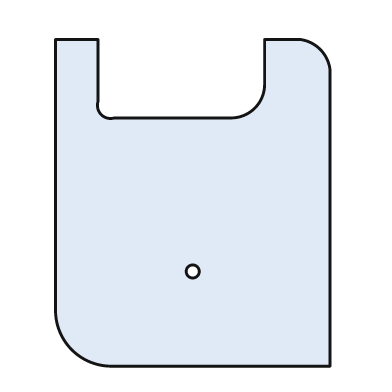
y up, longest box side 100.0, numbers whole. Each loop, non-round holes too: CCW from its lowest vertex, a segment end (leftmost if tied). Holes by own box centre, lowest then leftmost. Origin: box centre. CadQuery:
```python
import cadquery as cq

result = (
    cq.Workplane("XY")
    .moveTo(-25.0, -50.0)
    .lineTo(42.0, -50.0)
    .lineTo(42.0, 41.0)
    .threePointArc((39.0, 47.0), (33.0, 50.0))
    .lineTo(22.0, 50.0)
    .lineTo(22.0, 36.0)
    .threePointArc((19.0, 29.0), (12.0, 26.0))
    .lineTo(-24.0, 26.0)
    .threePointArc((-28.0, 27.0), (-29.0, 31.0))
    .lineTo(-29.0, 50.0)
    .lineTo(-42.0, 50.0)
    .lineTo(-42.0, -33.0)
    .threePointArc((-37.0, -45.0), (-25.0, -50.0))
    .close()
    .moveTo(0.0, -21.0)
    .circle(2.0)
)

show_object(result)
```